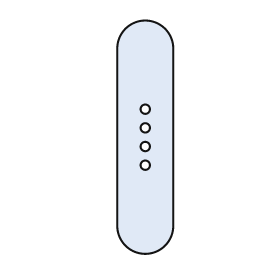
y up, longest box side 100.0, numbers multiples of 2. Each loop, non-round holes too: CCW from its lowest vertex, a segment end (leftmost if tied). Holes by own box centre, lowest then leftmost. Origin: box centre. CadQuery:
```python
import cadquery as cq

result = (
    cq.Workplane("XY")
    .moveTo(-12.0, -38.0)
    .threePointArc((0.0, -50.0), (12.0, -38.0))
    .lineTo(12.0, 38.0)
    .threePointArc((0.0, 50.0), (-12.0, 38.0))
    .close()
    .moveTo(0.0, -12.0)
    .circle(2.0)
    .moveTo(0.0, -4.0)
    .circle(2.0)
    .moveTo(0.0, 4.0)
    .circle(2.0)
    .moveTo(0.0, 12.0)
    .circle(2.0)
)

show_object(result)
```